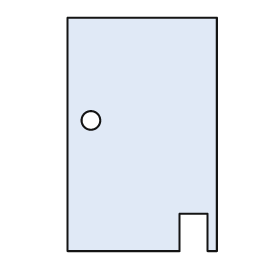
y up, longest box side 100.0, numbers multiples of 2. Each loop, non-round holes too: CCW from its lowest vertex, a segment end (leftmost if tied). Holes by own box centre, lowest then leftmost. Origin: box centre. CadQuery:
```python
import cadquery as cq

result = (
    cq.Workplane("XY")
    .moveTo(-32.0, -50.0)
    .lineTo(16.0, -50.0)
    .lineTo(16.0, -34.0)
    .lineTo(28.0, -34.0)
    .lineTo(28.0, -50.0)
    .lineTo(32.0, -50.0)
    .lineTo(32.0, 50.0)
    .lineTo(-32.0, 50.0)
    .close()
    .moveTo(-22.0, 6.0)
    .circle(4.0)
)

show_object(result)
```